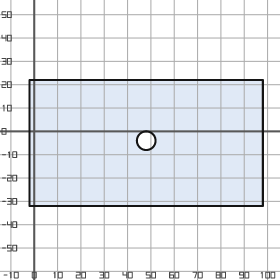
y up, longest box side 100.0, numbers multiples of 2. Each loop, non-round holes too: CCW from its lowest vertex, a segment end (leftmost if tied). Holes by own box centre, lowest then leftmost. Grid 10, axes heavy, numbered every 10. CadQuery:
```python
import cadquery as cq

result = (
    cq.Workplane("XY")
    .moveTo(-2.0, -32.0)
    .lineTo(98.0, -32.0)
    .lineTo(98.0, 22.0)
    .lineTo(-2.0, 22.0)
    .close()
    .moveTo(48.0, -4.0)
    .circle(4.0)
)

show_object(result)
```